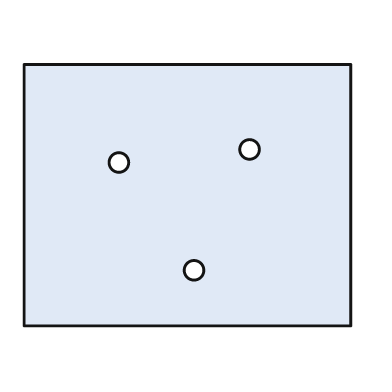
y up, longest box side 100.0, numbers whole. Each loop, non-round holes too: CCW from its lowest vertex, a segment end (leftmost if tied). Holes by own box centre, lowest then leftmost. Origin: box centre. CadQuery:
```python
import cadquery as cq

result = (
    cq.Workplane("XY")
    .moveTo(-50.0, -40.0)
    .lineTo(50.0, -40.0)
    .lineTo(50.0, 40.0)
    .lineTo(-50.0, 40.0)
    .close()
    .moveTo(2.0, -23.0)
    .circle(3.0)
    .moveTo(-21.0, 10.0)
    .circle(3.0)
    .moveTo(19.0, 14.0)
    .circle(3.0)
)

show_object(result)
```